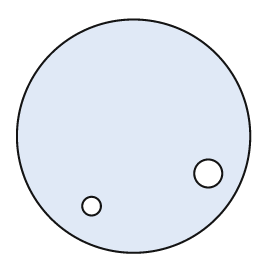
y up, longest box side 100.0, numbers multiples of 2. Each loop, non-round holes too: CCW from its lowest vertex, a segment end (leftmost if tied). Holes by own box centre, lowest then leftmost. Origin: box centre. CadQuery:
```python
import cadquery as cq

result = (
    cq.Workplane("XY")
    .moveTo(0.0, 0.0)
    .circle(50.0)
    .moveTo(-18.0, -30.0)
    .circle(4.0)
    .moveTo(32.0, -16.0)
    .circle(6.0)
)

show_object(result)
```